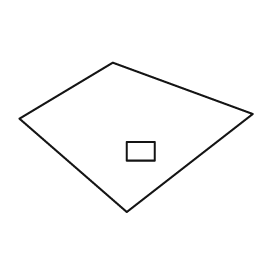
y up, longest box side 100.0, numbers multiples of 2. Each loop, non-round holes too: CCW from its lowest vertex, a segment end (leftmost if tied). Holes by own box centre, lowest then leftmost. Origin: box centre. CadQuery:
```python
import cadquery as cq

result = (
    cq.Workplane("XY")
    .moveTo(-4.0, -32.0)
    .lineTo(50.0, 10.0)
    .lineTo(-10.0, 32.0)
    .lineTo(-50.0, 8.0)
    .close()
    .moveTo(-4.0, -10.0)
    .lineTo(8.0, -10.0)
    .lineTo(8.0, -2.0)
    .lineTo(-4.0, -2.0)
    .close()
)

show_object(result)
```